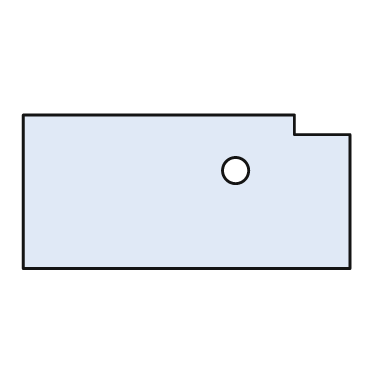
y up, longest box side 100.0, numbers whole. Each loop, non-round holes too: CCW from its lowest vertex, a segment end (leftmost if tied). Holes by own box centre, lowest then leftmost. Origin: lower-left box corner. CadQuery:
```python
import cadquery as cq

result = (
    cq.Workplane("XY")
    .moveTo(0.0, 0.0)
    .lineTo(100.0, 0.0)
    .lineTo(100.0, 41.0)
    .lineTo(83.0, 41.0)
    .lineTo(83.0, 47.0)
    .lineTo(0.0, 47.0)
    .close()
    .moveTo(65.0, 30.0)
    .circle(4.0)
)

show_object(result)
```